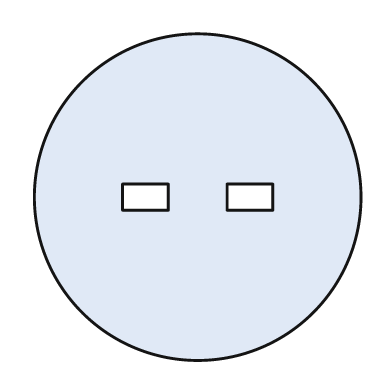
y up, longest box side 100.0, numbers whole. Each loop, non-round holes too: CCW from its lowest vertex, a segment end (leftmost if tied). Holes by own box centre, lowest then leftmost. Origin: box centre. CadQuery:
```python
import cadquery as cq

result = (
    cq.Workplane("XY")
    .moveTo(0.0, 0.0)
    .circle(50.0)
    .moveTo(-23.0, -4.0)
    .lineTo(-9.0, -4.0)
    .lineTo(-9.0, 4.0)
    .lineTo(-23.0, 4.0)
    .close()
    .moveTo(9.0, -4.0)
    .lineTo(23.0, -4.0)
    .lineTo(23.0, 4.0)
    .lineTo(9.0, 4.0)
    .close()
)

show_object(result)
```